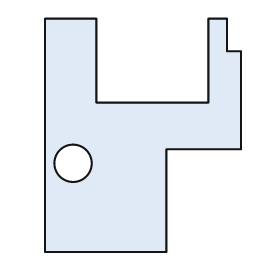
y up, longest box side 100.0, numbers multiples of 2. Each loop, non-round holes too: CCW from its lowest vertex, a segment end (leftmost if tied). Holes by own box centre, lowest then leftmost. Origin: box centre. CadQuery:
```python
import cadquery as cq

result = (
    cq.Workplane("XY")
    .moveTo(-42.0, -50.0)
    .lineTo(10.0, -50.0)
    .lineTo(10.0, -6.0)
    .lineTo(42.0, -6.0)
    .lineTo(42.0, 36.0)
    .lineTo(36.0, 36.0)
    .lineTo(36.0, 50.0)
    .lineTo(28.0, 50.0)
    .lineTo(28.0, 14.0)
    .lineTo(-20.0, 14.0)
    .lineTo(-20.0, 50.0)
    .lineTo(-42.0, 50.0)
    .close()
    .moveTo(-30.0, -12.0)
    .circle(8.0)
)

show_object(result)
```